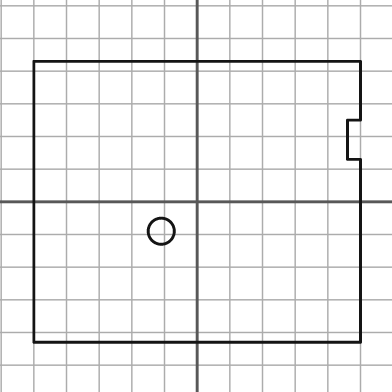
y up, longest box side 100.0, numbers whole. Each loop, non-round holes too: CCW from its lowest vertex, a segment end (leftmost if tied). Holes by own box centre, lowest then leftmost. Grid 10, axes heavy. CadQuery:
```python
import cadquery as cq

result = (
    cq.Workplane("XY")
    .moveTo(-50.0, -43.0)
    .lineTo(50.0, -43.0)
    .lineTo(50.0, 13.0)
    .lineTo(46.0, 13.0)
    .lineTo(46.0, 25.0)
    .lineTo(50.0, 25.0)
    .lineTo(50.0, 43.0)
    .lineTo(-50.0, 43.0)
    .close()
    .moveTo(-11.0, -9.0)
    .circle(4.0)
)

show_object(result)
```